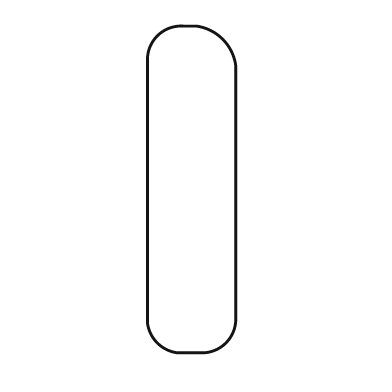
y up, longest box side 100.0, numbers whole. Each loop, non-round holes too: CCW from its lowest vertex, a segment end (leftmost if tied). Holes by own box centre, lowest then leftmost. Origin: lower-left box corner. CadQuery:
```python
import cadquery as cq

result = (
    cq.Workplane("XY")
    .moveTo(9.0, 0.0)
    .lineTo(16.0, 0.0)
    .threePointArc((24.0, 3.0), (27.0, 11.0))
    .lineTo(27.0, 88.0)
    .threePointArc((23.0, 96.0), (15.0, 100.0))
    .lineTo(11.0, 100.0)
    .threePointArc((3.0, 97.0), (0.0, 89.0))
    .lineTo(0.0, 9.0)
    .threePointArc((3.0, 3.0), (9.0, 0.0))
    .close()
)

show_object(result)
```